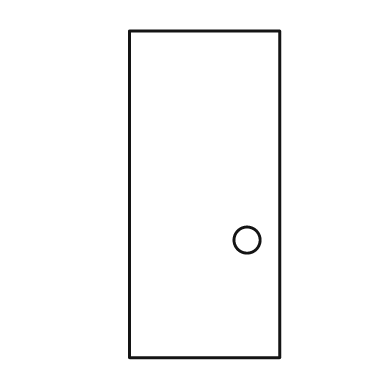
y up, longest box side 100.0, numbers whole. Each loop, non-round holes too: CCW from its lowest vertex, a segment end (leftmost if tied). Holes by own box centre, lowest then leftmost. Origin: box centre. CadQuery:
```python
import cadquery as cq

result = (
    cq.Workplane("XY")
    .moveTo(-23.0, -50.0)
    .lineTo(23.0, -50.0)
    .lineTo(23.0, 50.0)
    .lineTo(-23.0, 50.0)
    .close()
    .moveTo(13.0, -14.0)
    .circle(4.0)
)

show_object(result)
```